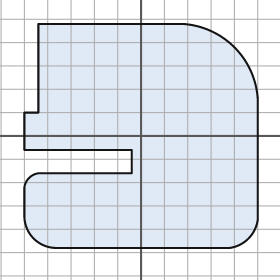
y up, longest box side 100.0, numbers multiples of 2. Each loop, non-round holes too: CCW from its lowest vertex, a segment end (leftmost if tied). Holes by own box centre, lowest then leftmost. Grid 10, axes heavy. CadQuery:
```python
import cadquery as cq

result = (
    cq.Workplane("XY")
    .moveTo(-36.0, -48.0)
    .lineTo(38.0, -48.0)
    .threePointArc((46.0, -44.0), (50.0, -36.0))
    .lineTo(50.0, 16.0)
    .threePointArc((40.0, 38.0), (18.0, 48.0))
    .lineTo(-44.0, 48.0)
    .lineTo(-44.0, 10.0)
    .lineTo(-50.0, 10.0)
    .lineTo(-50.0, -6.0)
    .lineTo(-4.0, -6.0)
    .lineTo(-4.0, -16.0)
    .lineTo(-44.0, -16.0)
    .threePointArc((-48.0, -18.0), (-50.0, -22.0))
    .lineTo(-50.0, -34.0)
    .threePointArc((-46.0, -44.0), (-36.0, -48.0))
    .close()
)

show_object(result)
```